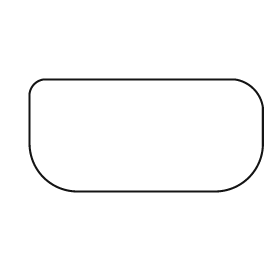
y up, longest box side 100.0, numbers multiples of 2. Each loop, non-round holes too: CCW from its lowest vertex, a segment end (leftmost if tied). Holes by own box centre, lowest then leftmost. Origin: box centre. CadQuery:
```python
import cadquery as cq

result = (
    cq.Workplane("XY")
    .moveTo(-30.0, -24.0)
    .lineTo(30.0, -24.0)
    .threePointArc((44.0, -18.0), (50.0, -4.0))
    .lineTo(50.0, 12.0)
    .threePointArc((46.0, 20.0), (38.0, 24.0))
    .lineTo(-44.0, 24.0)
    .threePointArc((-48.0, 22.0), (-50.0, 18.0))
    .lineTo(-50.0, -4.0)
    .threePointArc((-44.0, -18.0), (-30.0, -24.0))
    .close()
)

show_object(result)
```